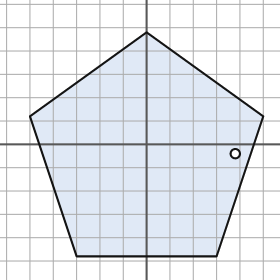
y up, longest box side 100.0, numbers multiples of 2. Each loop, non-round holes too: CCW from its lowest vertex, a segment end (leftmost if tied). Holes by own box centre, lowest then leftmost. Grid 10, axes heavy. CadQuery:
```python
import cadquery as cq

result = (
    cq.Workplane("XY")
    .moveTo(-30.0, -48.0)
    .lineTo(30.0, -48.0)
    .lineTo(50.0, 12.0)
    .lineTo(0.0, 48.0)
    .lineTo(-50.0, 12.0)
    .close()
    .moveTo(38.0, -4.0)
    .circle(2.0)
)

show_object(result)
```